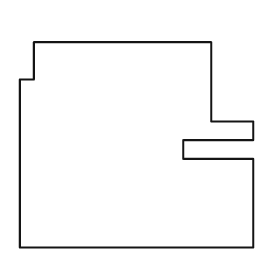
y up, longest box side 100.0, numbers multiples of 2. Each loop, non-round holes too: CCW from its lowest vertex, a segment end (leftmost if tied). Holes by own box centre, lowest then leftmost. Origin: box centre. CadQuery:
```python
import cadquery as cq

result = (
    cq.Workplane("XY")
    .moveTo(-50.0, -44.0)
    .lineTo(50.0, -44.0)
    .lineTo(50.0, -6.0)
    .lineTo(20.0, -6.0)
    .lineTo(20.0, 2.0)
    .lineTo(50.0, 2.0)
    .lineTo(50.0, 10.0)
    .lineTo(32.0, 10.0)
    .lineTo(32.0, 44.0)
    .lineTo(-44.0, 44.0)
    .lineTo(-44.0, 28.0)
    .lineTo(-50.0, 28.0)
    .close()
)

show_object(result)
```